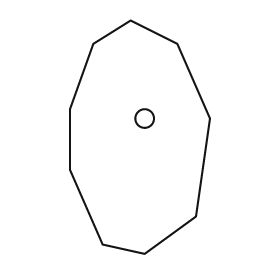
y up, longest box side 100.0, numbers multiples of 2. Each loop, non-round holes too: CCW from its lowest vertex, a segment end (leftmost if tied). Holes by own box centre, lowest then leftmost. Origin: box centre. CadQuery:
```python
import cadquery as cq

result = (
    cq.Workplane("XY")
    .moveTo(2.0, -50.0)
    .lineTo(24.0, -34.0)
    .lineTo(30.0, 8.0)
    .lineTo(16.0, 40.0)
    .lineTo(-4.0, 50.0)
    .lineTo(-20.0, 40.0)
    .lineTo(-30.0, 12.0)
    .lineTo(-30.0, -14.0)
    .lineTo(-16.0, -46.0)
    .close()
    .moveTo(2.0, 8.0)
    .circle(4.0)
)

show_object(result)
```